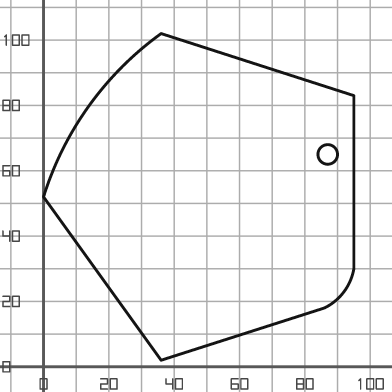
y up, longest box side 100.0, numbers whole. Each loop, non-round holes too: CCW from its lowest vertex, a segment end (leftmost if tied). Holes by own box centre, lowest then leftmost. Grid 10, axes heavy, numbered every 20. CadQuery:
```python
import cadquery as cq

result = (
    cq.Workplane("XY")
    .moveTo(36.0, 2.0)
    .lineTo(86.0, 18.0)
    .threePointArc((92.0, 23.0), (95.0, 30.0))
    .lineTo(95.0, 83.0)
    .lineTo(36.0, 102.0)
    .threePointArc((14.0, 80.0), (0.0, 52.0))
    .close()
    .moveTo(87.0, 65.0)
    .circle(3.0)
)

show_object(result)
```